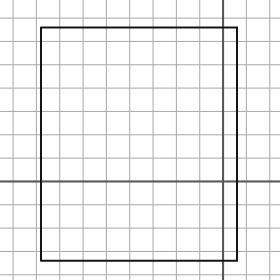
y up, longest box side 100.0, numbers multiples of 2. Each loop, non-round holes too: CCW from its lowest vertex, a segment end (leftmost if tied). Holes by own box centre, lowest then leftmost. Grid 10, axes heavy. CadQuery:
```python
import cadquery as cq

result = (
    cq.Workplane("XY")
    .moveTo(-78.0, -34.0)
    .lineTo(6.0, -34.0)
    .lineTo(6.0, 66.0)
    .lineTo(-78.0, 66.0)
    .close()
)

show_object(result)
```